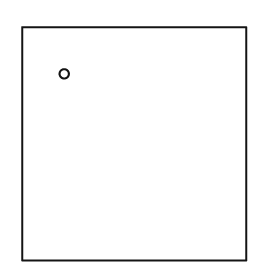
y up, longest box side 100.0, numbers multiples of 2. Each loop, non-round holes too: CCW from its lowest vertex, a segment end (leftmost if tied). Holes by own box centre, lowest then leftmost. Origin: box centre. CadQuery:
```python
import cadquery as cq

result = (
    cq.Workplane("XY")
    .moveTo(-48.0, -50.0)
    .lineTo(48.0, -50.0)
    .lineTo(48.0, 50.0)
    .lineTo(-48.0, 50.0)
    .close()
    .moveTo(-30.0, 30.0)
    .circle(2.0)
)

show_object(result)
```